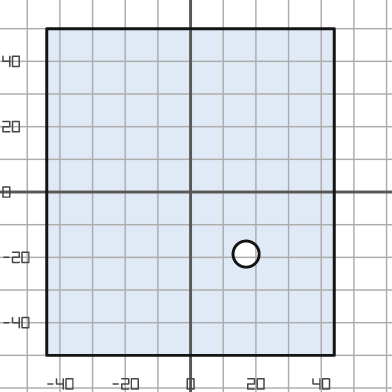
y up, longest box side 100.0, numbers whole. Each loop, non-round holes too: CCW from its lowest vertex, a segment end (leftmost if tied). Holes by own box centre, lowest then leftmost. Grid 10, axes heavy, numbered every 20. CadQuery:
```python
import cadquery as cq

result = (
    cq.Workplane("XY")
    .moveTo(-44.0, -50.0)
    .lineTo(44.0, -50.0)
    .lineTo(44.0, 50.0)
    .lineTo(-44.0, 50.0)
    .close()
    .moveTo(17.0, -19.0)
    .circle(4.0)
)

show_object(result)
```